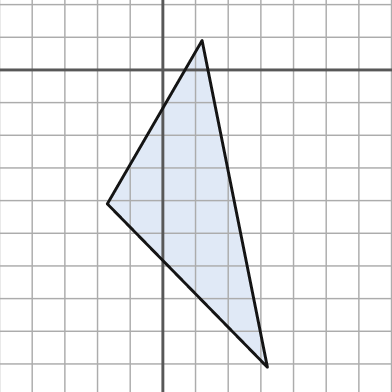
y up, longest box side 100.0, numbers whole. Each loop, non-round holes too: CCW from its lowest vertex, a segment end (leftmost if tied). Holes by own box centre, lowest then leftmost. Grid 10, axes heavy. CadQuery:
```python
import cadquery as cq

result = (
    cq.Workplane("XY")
    .moveTo(32.0, -91.0)
    .lineTo(12.0, 9.0)
    .lineTo(-17.0, -41.0)
    .close()
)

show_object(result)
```